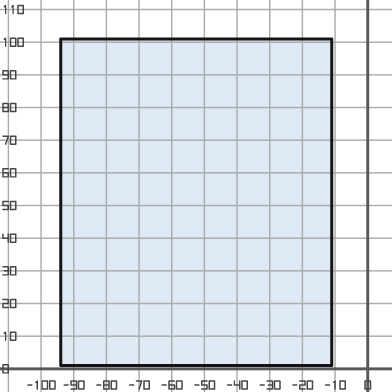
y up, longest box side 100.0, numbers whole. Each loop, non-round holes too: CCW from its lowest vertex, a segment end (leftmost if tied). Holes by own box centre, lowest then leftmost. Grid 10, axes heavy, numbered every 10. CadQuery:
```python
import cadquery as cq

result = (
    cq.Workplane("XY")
    .moveTo(-94.0, 1.0)
    .lineTo(-11.0, 1.0)
    .lineTo(-11.0, 101.0)
    .lineTo(-94.0, 101.0)
    .close()
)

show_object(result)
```